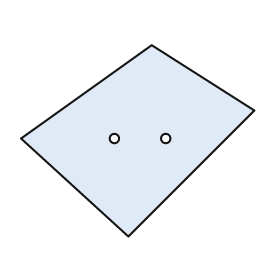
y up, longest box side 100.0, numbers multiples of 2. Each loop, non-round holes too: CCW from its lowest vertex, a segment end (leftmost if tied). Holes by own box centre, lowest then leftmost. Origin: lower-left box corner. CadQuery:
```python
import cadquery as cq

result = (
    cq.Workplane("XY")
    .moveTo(46.0, 0.0)
    .lineTo(100.0, 54.0)
    .lineTo(56.0, 82.0)
    .lineTo(0.0, 42.0)
    .close()
    .moveTo(40.0, 42.0)
    .circle(2.0)
    .moveTo(62.0, 42.0)
    .circle(2.0)
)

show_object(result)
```